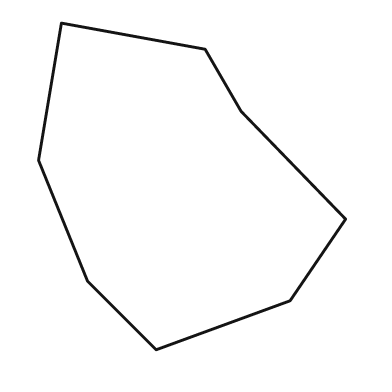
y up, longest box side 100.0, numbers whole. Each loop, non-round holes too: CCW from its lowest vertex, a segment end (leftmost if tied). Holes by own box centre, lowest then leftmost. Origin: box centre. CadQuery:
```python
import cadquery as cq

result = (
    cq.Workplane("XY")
    .moveTo(-11.0, -50.0)
    .lineTo(30.0, -35.0)
    .lineTo(47.0, -10.0)
    .lineTo(15.0, 23.0)
    .lineTo(4.0, 42.0)
    .lineTo(-40.0, 50.0)
    .lineTo(-47.0, 8.0)
    .lineTo(-32.0, -29.0)
    .close()
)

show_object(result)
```